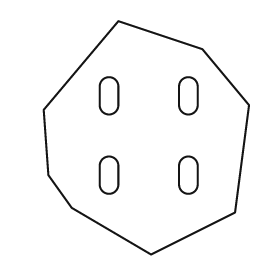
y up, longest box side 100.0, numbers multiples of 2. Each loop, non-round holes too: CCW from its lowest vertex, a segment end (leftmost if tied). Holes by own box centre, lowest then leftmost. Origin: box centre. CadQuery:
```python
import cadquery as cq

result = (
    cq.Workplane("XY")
    .moveTo(2.0, -50.0)
    .lineTo(38.0, -32.0)
    .lineTo(44.0, 14.0)
    .lineTo(24.0, 38.0)
    .lineTo(-12.0, 50.0)
    .lineTo(-44.0, 12.0)
    .lineTo(-42.0, -16.0)
    .lineTo(-32.0, -30.0)
    .close()
    .moveTo(-20.0, -20.0)
    .threePointArc((-16.0, -24.0), (-12.0, -20.0))
    .lineTo(-12.0, -12.0)
    .threePointArc((-16.0, -8.0), (-20.0, -12.0))
    .close()
    .moveTo(14.0, -20.0)
    .threePointArc((18.0, -24.0), (22.0, -20.0))
    .lineTo(22.0, -12.0)
    .threePointArc((18.0, -8.0), (14.0, -12.0))
    .close()
    .moveTo(-20.0, 14.0)
    .threePointArc((-16.0, 10.0), (-12.0, 14.0))
    .lineTo(-12.0, 22.0)
    .threePointArc((-16.0, 26.0), (-20.0, 22.0))
    .close()
    .moveTo(14.0, 14.0)
    .threePointArc((18.0, 10.0), (22.0, 14.0))
    .lineTo(22.0, 22.0)
    .threePointArc((18.0, 26.0), (14.0, 22.0))
    .close()
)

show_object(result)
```